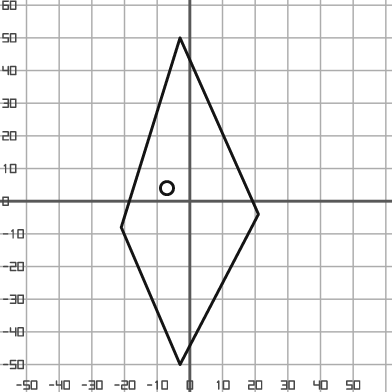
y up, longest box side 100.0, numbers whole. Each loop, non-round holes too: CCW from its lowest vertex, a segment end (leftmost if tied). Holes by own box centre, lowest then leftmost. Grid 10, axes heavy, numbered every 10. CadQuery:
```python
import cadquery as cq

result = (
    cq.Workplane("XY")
    .moveTo(-3.0, -50.0)
    .lineTo(21.0, -4.0)
    .lineTo(-3.0, 50.0)
    .lineTo(-21.0, -8.0)
    .close()
    .moveTo(-7.0, 4.0)
    .circle(2.0)
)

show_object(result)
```